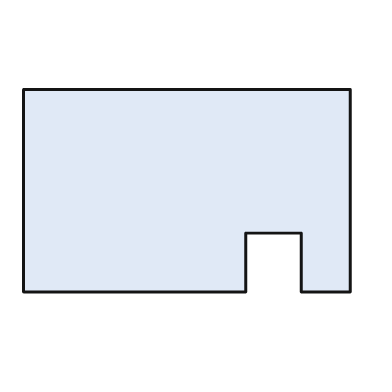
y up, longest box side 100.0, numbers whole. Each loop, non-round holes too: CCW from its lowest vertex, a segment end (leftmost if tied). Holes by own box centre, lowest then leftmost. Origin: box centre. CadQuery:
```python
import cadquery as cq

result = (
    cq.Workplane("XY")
    .moveTo(-50.0, -31.0)
    .lineTo(18.0, -31.0)
    .lineTo(18.0, -13.0)
    .lineTo(35.0, -13.0)
    .lineTo(35.0, -31.0)
    .lineTo(50.0, -31.0)
    .lineTo(50.0, 31.0)
    .lineTo(-50.0, 31.0)
    .close()
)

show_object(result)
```